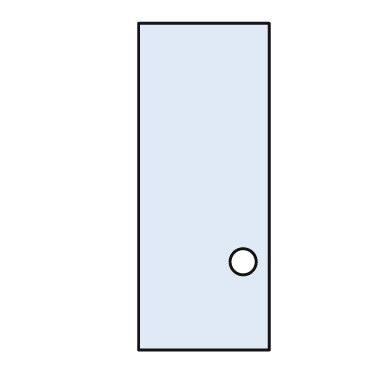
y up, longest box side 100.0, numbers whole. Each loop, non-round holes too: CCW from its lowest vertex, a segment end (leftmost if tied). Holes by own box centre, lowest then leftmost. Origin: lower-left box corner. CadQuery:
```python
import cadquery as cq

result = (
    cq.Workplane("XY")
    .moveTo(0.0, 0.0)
    .lineTo(40.0, 0.0)
    .lineTo(40.0, 100.0)
    .lineTo(0.0, 100.0)
    .close()
    .moveTo(32.0, 27.0)
    .circle(4.0)
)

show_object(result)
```